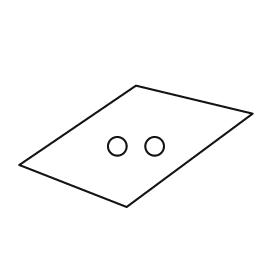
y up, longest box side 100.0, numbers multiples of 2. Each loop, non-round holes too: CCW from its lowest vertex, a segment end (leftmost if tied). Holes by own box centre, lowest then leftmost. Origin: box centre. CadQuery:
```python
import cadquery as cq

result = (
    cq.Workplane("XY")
    .moveTo(-4.0, -26.0)
    .lineTo(50.0, 14.0)
    .lineTo(0.0, 26.0)
    .lineTo(-50.0, -8.0)
    .close()
    .moveTo(-8.0, 0.0)
    .circle(4.0)
    .moveTo(8.0, 0.0)
    .circle(4.0)
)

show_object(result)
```